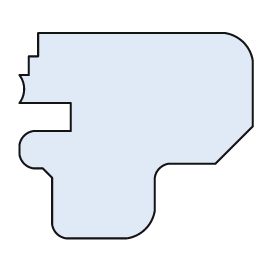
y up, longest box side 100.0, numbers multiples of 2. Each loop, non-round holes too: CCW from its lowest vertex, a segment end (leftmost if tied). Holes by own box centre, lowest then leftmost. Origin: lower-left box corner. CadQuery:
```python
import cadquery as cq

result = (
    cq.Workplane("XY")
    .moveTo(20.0, 0.0)
    .lineTo(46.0, 0.0)
    .threePointArc((54.0, 4.0), (58.0, 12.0))
    .lineTo(58.0, 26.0)
    .threePointArc((60.0, 30.0), (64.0, 32.0))
    .lineTo(84.0, 32.0)
    .lineTo(100.0, 48.0)
    .lineTo(100.0, 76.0)
    .threePointArc((96.0, 84.0), (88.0, 88.0))
    .lineTo(8.0, 88.0)
    .lineTo(8.0, 78.0)
    .lineTo(4.0, 78.0)
    .lineTo(4.0, 70.0)
    .lineTo(0.0, 70.0)
    .threePointArc((2.0, 64.0), (0.0, 58.0))
    .lineTo(22.0, 58.0)
    .lineTo(22.0, 46.0)
    .lineTo(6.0, 46.0)
    .threePointArc((2.0, 44.0), (0.0, 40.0))
    .lineTo(0.0, 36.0)
    .threePointArc((2.0, 32.0), (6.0, 30.0))
    .lineTo(10.0, 30.0)
    .lineTo(14.0, 26.0)
    .lineTo(14.0, 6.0)
    .threePointArc((16.0, 2.0), (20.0, 0.0))
    .close()
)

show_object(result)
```